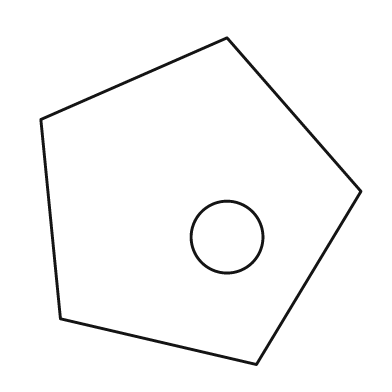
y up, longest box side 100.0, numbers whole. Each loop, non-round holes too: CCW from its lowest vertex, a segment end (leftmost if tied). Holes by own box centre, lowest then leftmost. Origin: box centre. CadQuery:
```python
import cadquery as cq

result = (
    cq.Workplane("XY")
    .moveTo(17.0, -50.0)
    .lineTo(49.0, 3.0)
    .lineTo(8.0, 50.0)
    .lineTo(-49.0, 25.0)
    .lineTo(-43.0, -36.0)
    .close()
    .moveTo(8.0, -11.0)
    .circle(11.0)
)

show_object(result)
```